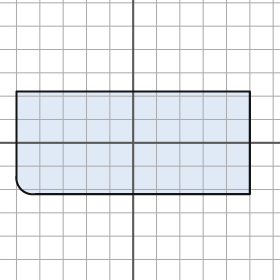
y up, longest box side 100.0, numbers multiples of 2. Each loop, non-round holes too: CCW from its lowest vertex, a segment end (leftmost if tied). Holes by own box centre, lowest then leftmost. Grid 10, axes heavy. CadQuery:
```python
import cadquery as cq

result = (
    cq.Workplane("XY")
    .moveTo(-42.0, -22.0)
    .lineTo(50.0, -22.0)
    .lineTo(50.0, 22.0)
    .lineTo(-50.0, 22.0)
    .lineTo(-50.0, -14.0)
    .threePointArc((-48.0, -20.0), (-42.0, -22.0))
    .close()
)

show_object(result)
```